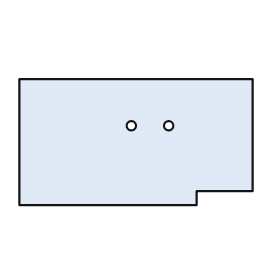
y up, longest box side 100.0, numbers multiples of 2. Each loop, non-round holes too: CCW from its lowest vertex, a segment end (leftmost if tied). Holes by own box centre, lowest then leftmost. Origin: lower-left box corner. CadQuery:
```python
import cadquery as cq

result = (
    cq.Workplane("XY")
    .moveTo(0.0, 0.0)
    .lineTo(76.0, 0.0)
    .lineTo(76.0, 6.0)
    .lineTo(100.0, 6.0)
    .lineTo(100.0, 54.0)
    .lineTo(0.0, 54.0)
    .close()
    .moveTo(48.0, 34.0)
    .circle(2.0)
    .moveTo(64.0, 34.0)
    .circle(2.0)
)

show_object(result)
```